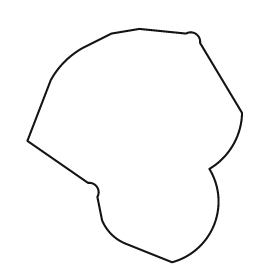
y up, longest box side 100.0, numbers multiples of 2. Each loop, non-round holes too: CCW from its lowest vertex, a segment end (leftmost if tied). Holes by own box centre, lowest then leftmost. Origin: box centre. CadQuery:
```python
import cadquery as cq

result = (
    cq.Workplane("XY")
    .moveTo(16.0, -50.0)
    .threePointArc((34.0, -34.0), (32.0, -10.0))
    .threePointArc((42.0, 0.0), (46.0, 14.0))
    .lineTo(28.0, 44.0)
    .threePointArc((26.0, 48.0), (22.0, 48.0))
    .lineTo(2.0, 50.0)
    .lineTo(-10.0, 48.0)
    .lineTo(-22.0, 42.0)
    .threePointArc((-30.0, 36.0), (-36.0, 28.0))
    .lineTo(-46.0, 2.0)
    .lineTo(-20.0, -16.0)
    .threePointArc((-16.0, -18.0), (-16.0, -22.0))
    .lineTo(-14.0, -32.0)
    .threePointArc((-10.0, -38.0), (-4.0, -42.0))
    .close()
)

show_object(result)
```